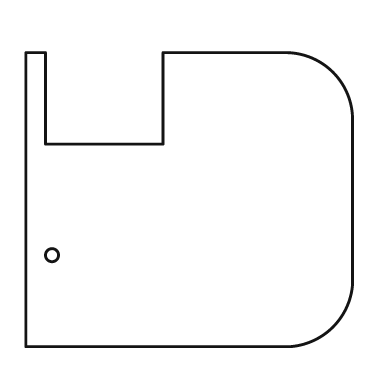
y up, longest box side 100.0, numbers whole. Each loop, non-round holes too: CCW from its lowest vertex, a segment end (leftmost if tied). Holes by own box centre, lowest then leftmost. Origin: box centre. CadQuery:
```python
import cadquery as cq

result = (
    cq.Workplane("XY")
    .moveTo(-50.0, -45.0)
    .lineTo(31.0, -45.0)
    .threePointArc((44.0, -39.0), (50.0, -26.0))
    .lineTo(50.0, 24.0)
    .threePointArc((44.0, 39.0), (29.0, 45.0))
    .lineTo(-8.0, 45.0)
    .lineTo(-8.0, 17.0)
    .lineTo(-44.0, 17.0)
    .lineTo(-44.0, 45.0)
    .lineTo(-50.0, 45.0)
    .close()
    .moveTo(-42.0, -17.0)
    .circle(2.0)
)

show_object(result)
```